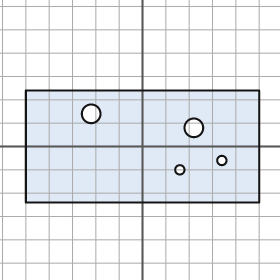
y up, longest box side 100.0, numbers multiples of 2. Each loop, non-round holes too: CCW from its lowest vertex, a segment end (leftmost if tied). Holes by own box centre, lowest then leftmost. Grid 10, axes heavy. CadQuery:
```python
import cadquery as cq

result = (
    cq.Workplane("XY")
    .moveTo(-50.0, -24.0)
    .lineTo(50.0, -24.0)
    .lineTo(50.0, 24.0)
    .lineTo(-50.0, 24.0)
    .close()
    .moveTo(16.0, -10.0)
    .circle(2.0)
    .moveTo(34.0, -6.0)
    .circle(2.0)
    .moveTo(22.0, 8.0)
    .circle(4.0)
    .moveTo(-22.0, 14.0)
    .circle(4.0)
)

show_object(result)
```